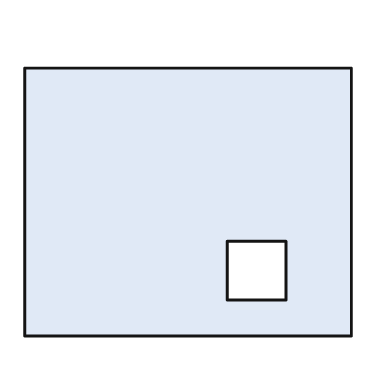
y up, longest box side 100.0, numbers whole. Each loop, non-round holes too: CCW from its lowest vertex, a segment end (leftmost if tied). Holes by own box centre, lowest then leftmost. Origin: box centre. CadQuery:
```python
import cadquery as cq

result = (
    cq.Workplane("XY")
    .moveTo(-50.0, -41.0)
    .lineTo(50.0, -41.0)
    .lineTo(50.0, 41.0)
    .lineTo(-50.0, 41.0)
    .close()
    .moveTo(12.0, -30.0)
    .lineTo(30.0, -30.0)
    .lineTo(30.0, -12.0)
    .lineTo(12.0, -12.0)
    .close()
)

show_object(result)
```